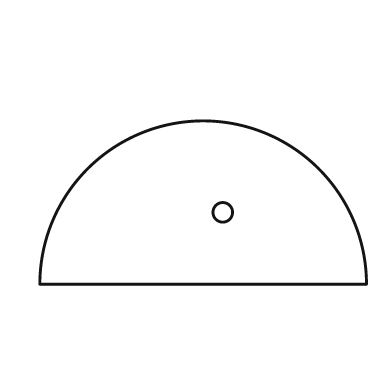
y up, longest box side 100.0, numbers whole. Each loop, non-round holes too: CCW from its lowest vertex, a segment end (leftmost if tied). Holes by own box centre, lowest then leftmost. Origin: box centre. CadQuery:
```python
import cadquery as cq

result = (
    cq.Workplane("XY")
    .moveTo(-50.0, -25.0)
    .lineTo(50.0, -25.0)
    .threePointArc((0.0, 25.0), (-50.0, -25.0))
    .close()
    .moveTo(6.0, -3.0)
    .circle(3.0)
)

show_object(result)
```